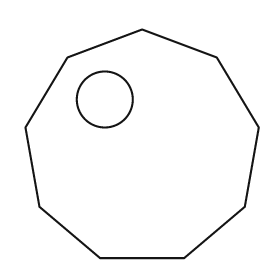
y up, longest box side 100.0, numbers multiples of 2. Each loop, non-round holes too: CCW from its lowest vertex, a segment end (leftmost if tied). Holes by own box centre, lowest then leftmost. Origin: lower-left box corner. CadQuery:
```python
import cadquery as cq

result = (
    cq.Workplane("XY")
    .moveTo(32.0, 0.0)
    .lineTo(68.0, 0.0)
    .lineTo(94.0, 22.0)
    .lineTo(100.0, 56.0)
    .lineTo(82.0, 86.0)
    .lineTo(50.0, 98.0)
    .lineTo(18.0, 86.0)
    .lineTo(0.0, 56.0)
    .lineTo(6.0, 22.0)
    .close()
    .moveTo(34.0, 68.0)
    .circle(12.0)
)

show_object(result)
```